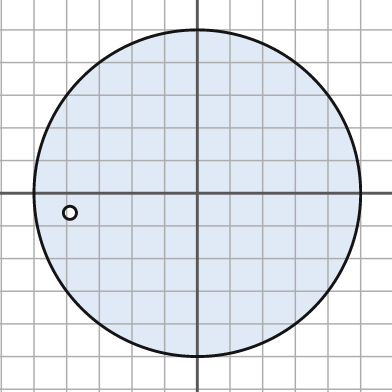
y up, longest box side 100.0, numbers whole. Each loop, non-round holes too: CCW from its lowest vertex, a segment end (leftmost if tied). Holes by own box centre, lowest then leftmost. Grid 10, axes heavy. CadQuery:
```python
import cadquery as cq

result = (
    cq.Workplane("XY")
    .moveTo(0.0, 0.0)
    .circle(50.0)
    .moveTo(-39.0, -6.0)
    .circle(2.0)
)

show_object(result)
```